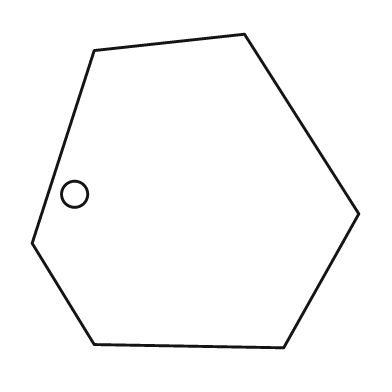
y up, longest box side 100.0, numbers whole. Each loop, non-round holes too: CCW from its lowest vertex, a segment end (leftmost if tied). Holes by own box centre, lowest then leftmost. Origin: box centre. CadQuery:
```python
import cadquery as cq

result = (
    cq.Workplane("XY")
    .moveTo(27.0, -48.0)
    .lineTo(50.0, -7.0)
    .lineTo(15.0, 48.0)
    .lineTo(-31.0, 43.0)
    .lineTo(-50.0, -16.0)
    .lineTo(-31.0, -47.0)
    .close()
    .moveTo(-37.0, -1.0)
    .circle(4.0)
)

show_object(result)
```